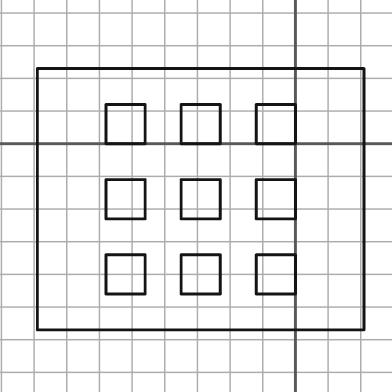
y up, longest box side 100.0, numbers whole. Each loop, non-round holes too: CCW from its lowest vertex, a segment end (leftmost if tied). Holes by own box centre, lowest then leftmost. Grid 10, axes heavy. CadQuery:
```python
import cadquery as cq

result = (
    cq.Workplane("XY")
    .moveTo(-79.0, -57.0)
    .lineTo(21.0, -57.0)
    .lineTo(21.0, 23.0)
    .lineTo(-79.0, 23.0)
    .close()
    .moveTo(-58.0, -46.0)
    .lineTo(-46.0, -46.0)
    .lineTo(-46.0, -34.0)
    .lineTo(-58.0, -34.0)
    .close()
    .moveTo(-35.0, -46.0)
    .lineTo(-23.0, -46.0)
    .lineTo(-23.0, -34.0)
    .lineTo(-35.0, -34.0)
    .close()
    .moveTo(-12.0, -46.0)
    .lineTo(0.0, -46.0)
    .lineTo(0.0, -34.0)
    .lineTo(-12.0, -34.0)
    .close()
    .moveTo(-58.0, -23.0)
    .lineTo(-46.0, -23.0)
    .lineTo(-46.0, -11.0)
    .lineTo(-58.0, -11.0)
    .close()
    .moveTo(-35.0, -23.0)
    .lineTo(-23.0, -23.0)
    .lineTo(-23.0, -11.0)
    .lineTo(-35.0, -11.0)
    .close()
    .moveTo(-12.0, -23.0)
    .lineTo(0.0, -23.0)
    .lineTo(0.0, -11.0)
    .lineTo(-12.0, -11.0)
    .close()
    .moveTo(-58.0, 0.0)
    .lineTo(-46.0, 0.0)
    .lineTo(-46.0, 12.0)
    .lineTo(-58.0, 12.0)
    .close()
    .moveTo(-35.0, 0.0)
    .lineTo(-23.0, 0.0)
    .lineTo(-23.0, 12.0)
    .lineTo(-35.0, 12.0)
    .close()
    .moveTo(-12.0, 0.0)
    .lineTo(0.0, 0.0)
    .lineTo(0.0, 12.0)
    .lineTo(-12.0, 12.0)
    .close()
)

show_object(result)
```